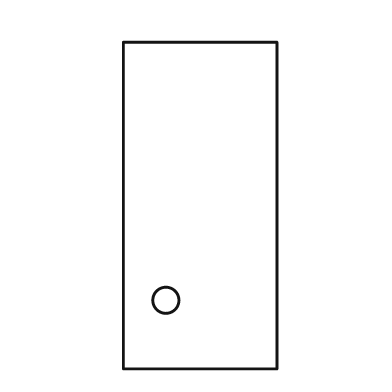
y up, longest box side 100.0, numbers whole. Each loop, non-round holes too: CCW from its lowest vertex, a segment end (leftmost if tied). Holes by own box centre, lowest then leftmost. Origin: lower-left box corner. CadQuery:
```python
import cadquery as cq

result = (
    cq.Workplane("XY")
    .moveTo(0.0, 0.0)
    .lineTo(47.0, 0.0)
    .lineTo(47.0, 100.0)
    .lineTo(0.0, 100.0)
    .close()
    .moveTo(13.0, 21.0)
    .circle(4.0)
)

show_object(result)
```